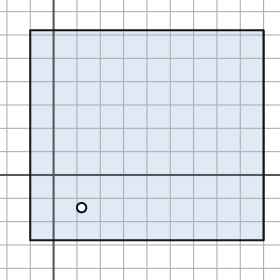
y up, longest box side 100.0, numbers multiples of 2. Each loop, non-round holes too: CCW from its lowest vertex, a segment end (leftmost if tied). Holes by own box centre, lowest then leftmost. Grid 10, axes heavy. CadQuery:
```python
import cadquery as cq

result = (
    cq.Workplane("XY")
    .moveTo(-10.0, -28.0)
    .lineTo(90.0, -28.0)
    .lineTo(90.0, 62.0)
    .lineTo(-10.0, 62.0)
    .close()
    .moveTo(12.0, -14.0)
    .circle(2.0)
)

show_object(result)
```